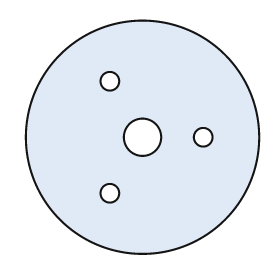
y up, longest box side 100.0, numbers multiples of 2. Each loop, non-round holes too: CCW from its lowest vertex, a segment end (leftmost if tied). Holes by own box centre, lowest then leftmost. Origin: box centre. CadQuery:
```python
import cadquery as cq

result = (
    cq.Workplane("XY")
    .moveTo(0.0, 0.0)
    .circle(50.0)
    .moveTo(-14.0, -24.0)
    .circle(4.0)
    .moveTo(0.0, 0.0)
    .circle(8.0)
    .moveTo(26.0, 0.0)
    .circle(4.0)
    .moveTo(-14.0, 24.0)
    .circle(4.0)
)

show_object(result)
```